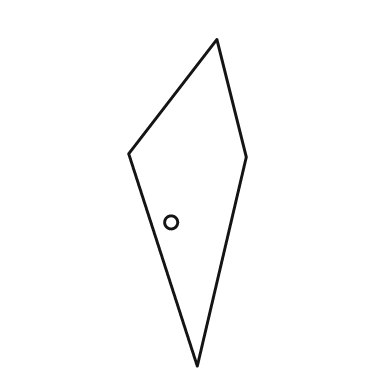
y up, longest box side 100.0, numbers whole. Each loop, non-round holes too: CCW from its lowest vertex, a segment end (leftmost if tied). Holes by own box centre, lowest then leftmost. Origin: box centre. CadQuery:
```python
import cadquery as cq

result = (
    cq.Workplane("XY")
    .moveTo(3.0, -50.0)
    .lineTo(18.0, 14.0)
    .lineTo(9.0, 50.0)
    .lineTo(-18.0, 15.0)
    .close()
    .moveTo(-5.0, -6.0)
    .circle(2.0)
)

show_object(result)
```